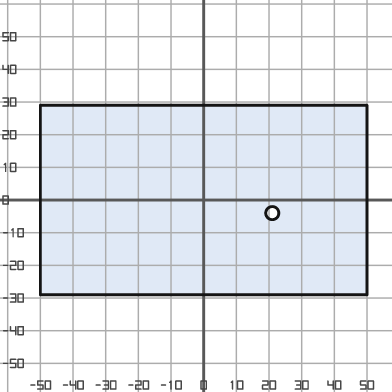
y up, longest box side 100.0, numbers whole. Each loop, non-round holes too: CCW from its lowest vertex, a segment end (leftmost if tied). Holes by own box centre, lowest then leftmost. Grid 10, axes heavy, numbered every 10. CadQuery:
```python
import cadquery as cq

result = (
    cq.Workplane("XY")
    .moveTo(-50.0, -29.0)
    .lineTo(50.0, -29.0)
    .lineTo(50.0, 29.0)
    .lineTo(-50.0, 29.0)
    .close()
    .moveTo(21.0, -4.0)
    .circle(2.0)
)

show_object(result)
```